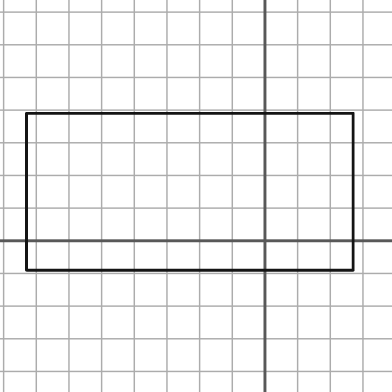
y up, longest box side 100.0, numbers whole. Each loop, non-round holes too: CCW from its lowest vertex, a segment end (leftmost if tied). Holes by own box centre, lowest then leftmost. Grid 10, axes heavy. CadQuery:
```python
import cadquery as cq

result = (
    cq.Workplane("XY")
    .moveTo(-73.0, -9.0)
    .lineTo(27.0, -9.0)
    .lineTo(27.0, 39.0)
    .lineTo(-73.0, 39.0)
    .close()
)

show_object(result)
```